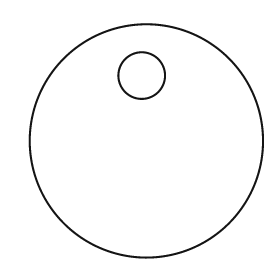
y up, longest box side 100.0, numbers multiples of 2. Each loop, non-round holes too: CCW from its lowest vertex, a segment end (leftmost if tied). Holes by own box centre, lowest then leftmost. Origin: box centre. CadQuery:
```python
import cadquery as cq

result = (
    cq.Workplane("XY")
    .moveTo(0.0, 0.0)
    .circle(50.0)
    .moveTo(-2.0, 28.0)
    .circle(10.0)
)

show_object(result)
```